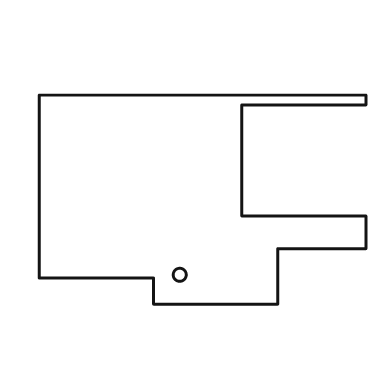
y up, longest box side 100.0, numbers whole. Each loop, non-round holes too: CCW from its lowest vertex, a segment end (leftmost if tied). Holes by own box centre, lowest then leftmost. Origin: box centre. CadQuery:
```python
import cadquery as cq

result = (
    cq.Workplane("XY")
    .moveTo(-15.0, -32.0)
    .lineTo(23.0, -32.0)
    .lineTo(23.0, -15.0)
    .lineTo(50.0, -15.0)
    .lineTo(50.0, -5.0)
    .lineTo(12.0, -5.0)
    .lineTo(12.0, 29.0)
    .lineTo(50.0, 29.0)
    .lineTo(50.0, 32.0)
    .lineTo(-50.0, 32.0)
    .lineTo(-50.0, -24.0)
    .lineTo(-15.0, -24.0)
    .close()
    .moveTo(-7.0, -23.0)
    .circle(2.0)
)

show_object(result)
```